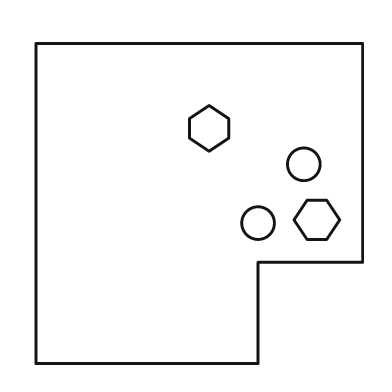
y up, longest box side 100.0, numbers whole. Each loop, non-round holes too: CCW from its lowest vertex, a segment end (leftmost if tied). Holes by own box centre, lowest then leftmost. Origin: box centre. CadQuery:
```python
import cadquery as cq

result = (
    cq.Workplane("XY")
    .moveTo(-50.0, -49.0)
    .lineTo(18.0, -49.0)
    .lineTo(18.0, -18.0)
    .lineTo(50.0, -18.0)
    .lineTo(50.0, 49.0)
    .lineTo(-50.0, 49.0)
    .close()
    .moveTo(18.0, -6.0)
    .circle(5.0)
    .moveTo(33.0, -11.0)
    .lineTo(39.0, -11.0)
    .lineTo(43.0, -5.0)
    .lineTo(39.0, 1.0)
    .lineTo(33.0, 1.0)
    .lineTo(29.0, -5.0)
    .close()
    .moveTo(32.0, 12.0)
    .circle(5.0)
    .moveTo(3.0, 16.0)
    .lineTo(9.0, 20.0)
    .lineTo(9.0, 26.0)
    .lineTo(3.0, 30.0)
    .lineTo(-3.0, 26.0)
    .lineTo(-3.0, 20.0)
    .close()
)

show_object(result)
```